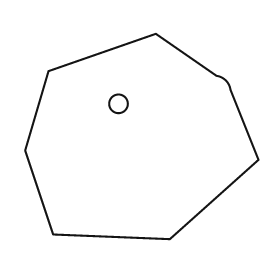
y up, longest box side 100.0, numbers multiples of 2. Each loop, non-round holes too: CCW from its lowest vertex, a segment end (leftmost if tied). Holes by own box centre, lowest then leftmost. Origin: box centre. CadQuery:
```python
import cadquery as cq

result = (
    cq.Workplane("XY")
    .moveTo(12.0, -44.0)
    .lineTo(50.0, -10.0)
    .lineTo(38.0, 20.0)
    .threePointArc((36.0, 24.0), (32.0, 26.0))
    .lineTo(6.0, 44.0)
    .lineTo(-40.0, 28.0)
    .lineTo(-50.0, -6.0)
    .lineTo(-38.0, -42.0)
    .close()
    .moveTo(-10.0, 14.0)
    .circle(4.0)
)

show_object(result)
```